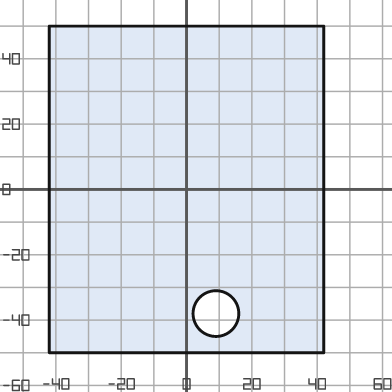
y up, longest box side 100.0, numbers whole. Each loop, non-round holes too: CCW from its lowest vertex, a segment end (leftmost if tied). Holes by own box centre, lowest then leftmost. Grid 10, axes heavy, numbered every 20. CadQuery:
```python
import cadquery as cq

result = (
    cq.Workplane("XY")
    .moveTo(-42.0, -50.0)
    .lineTo(42.0, -50.0)
    .lineTo(42.0, 50.0)
    .lineTo(-42.0, 50.0)
    .close()
    .moveTo(9.0, -38.0)
    .circle(7.0)
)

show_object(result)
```